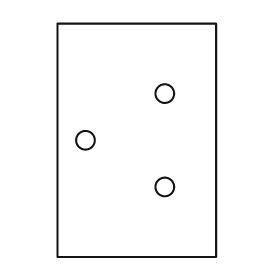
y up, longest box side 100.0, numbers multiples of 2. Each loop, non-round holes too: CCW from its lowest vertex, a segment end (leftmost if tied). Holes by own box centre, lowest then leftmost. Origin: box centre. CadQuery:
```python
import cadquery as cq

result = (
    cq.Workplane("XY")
    .moveTo(-34.0, -50.0)
    .lineTo(34.0, -50.0)
    .lineTo(34.0, 50.0)
    .lineTo(-34.0, 50.0)
    .close()
    .moveTo(12.0, -20.0)
    .circle(4.0)
    .moveTo(-22.0, 0.0)
    .circle(4.0)
    .moveTo(12.0, 20.0)
    .circle(4.0)
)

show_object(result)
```